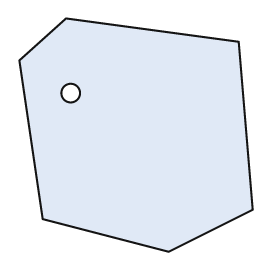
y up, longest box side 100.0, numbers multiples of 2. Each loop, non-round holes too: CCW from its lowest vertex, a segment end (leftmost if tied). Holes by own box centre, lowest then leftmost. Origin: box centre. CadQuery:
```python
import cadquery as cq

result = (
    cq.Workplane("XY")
    .moveTo(14.0, -50.0)
    .lineTo(50.0, -32.0)
    .lineTo(44.0, 40.0)
    .lineTo(-30.0, 50.0)
    .lineTo(-50.0, 32.0)
    .lineTo(-40.0, -36.0)
    .close()
    .moveTo(-28.0, 18.0)
    .circle(4.0)
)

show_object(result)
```